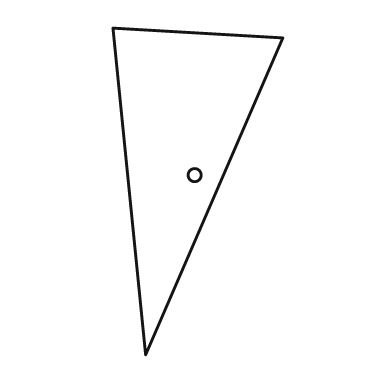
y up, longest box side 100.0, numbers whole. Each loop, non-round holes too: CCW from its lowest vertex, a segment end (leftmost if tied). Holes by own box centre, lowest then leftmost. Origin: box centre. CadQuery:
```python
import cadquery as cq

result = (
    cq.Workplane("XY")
    .moveTo(-16.0, -50.0)
    .lineTo(26.0, 47.0)
    .lineTo(-26.0, 50.0)
    .close()
    .moveTo(-1.0, 5.0)
    .circle(2.0)
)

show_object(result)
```